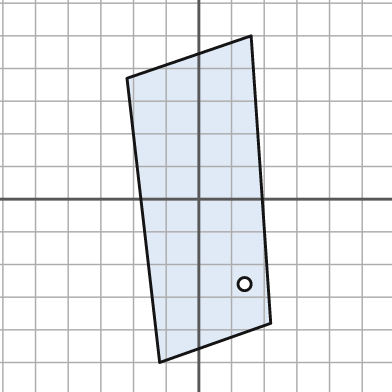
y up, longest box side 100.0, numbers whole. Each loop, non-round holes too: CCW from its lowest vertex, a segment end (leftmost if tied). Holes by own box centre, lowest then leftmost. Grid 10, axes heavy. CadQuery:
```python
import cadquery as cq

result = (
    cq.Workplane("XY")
    .moveTo(-12.0, -50.0)
    .lineTo(22.0, -38.0)
    .lineTo(16.0, 50.0)
    .lineTo(-22.0, 37.0)
    .close()
    .moveTo(14.0, -26.0)
    .circle(2.0)
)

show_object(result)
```